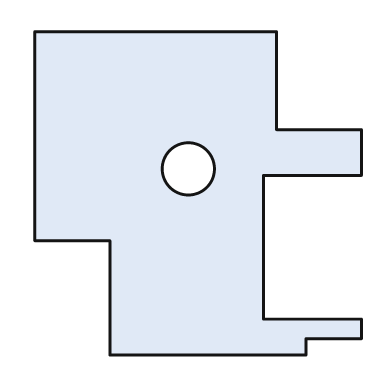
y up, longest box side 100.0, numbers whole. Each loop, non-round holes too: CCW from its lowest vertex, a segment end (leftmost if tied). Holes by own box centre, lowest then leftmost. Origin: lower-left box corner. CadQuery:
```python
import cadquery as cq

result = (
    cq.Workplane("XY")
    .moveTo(23.0, 0.0)
    .lineTo(83.0, 0.0)
    .lineTo(83.0, 5.0)
    .lineTo(100.0, 5.0)
    .lineTo(100.0, 11.0)
    .lineTo(70.0, 11.0)
    .lineTo(70.0, 55.0)
    .lineTo(100.0, 55.0)
    .lineTo(100.0, 69.0)
    .lineTo(74.0, 69.0)
    .lineTo(74.0, 99.0)
    .lineTo(0.0, 99.0)
    .lineTo(0.0, 35.0)
    .lineTo(23.0, 35.0)
    .close()
    .moveTo(47.0, 57.0)
    .circle(8.0)
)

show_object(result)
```